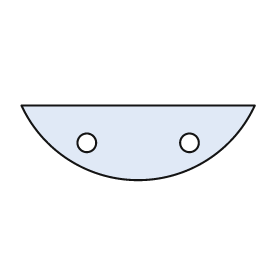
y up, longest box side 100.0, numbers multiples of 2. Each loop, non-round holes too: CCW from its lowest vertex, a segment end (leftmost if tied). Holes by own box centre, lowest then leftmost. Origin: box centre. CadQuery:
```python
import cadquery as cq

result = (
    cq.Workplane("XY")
    .moveTo(-50.0, 16.0)
    .threePointArc((0.0, -16.0), (50.0, 16.0))
    .close()
    .moveTo(-22.0, 0.0)
    .circle(4.0)
    .moveTo(22.0, 0.0)
    .circle(4.0)
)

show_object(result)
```